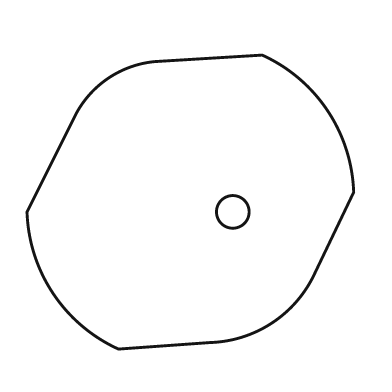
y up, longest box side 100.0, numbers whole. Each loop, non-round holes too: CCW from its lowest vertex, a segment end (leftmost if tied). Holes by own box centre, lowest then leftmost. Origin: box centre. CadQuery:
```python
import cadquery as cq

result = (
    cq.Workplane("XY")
    .moveTo(-22.0, -45.0)
    .lineTo(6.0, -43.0)
    .threePointArc((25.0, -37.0), (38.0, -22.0))
    .lineTo(50.0, 3.0)
    .threePointArc((42.0, 28.0), (22.0, 45.0))
    .lineTo(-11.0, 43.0)
    .threePointArc((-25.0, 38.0), (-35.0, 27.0))
    .lineTo(-50.0, -3.0)
    .threePointArc((-42.0, -28.0), (-22.0, -45.0))
    .close()
    .moveTo(13.0, -3.0)
    .circle(5.0)
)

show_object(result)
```